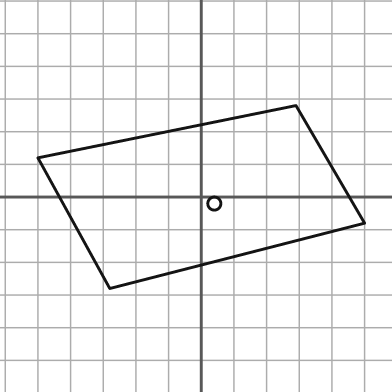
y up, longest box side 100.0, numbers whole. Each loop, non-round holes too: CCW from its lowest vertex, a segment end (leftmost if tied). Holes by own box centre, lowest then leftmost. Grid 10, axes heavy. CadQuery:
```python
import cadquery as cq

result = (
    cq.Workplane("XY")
    .moveTo(-28.0, -28.0)
    .lineTo(50.0, -8.0)
    .lineTo(29.0, 28.0)
    .lineTo(-50.0, 12.0)
    .close()
    .moveTo(4.0, -2.0)
    .circle(2.0)
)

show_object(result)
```